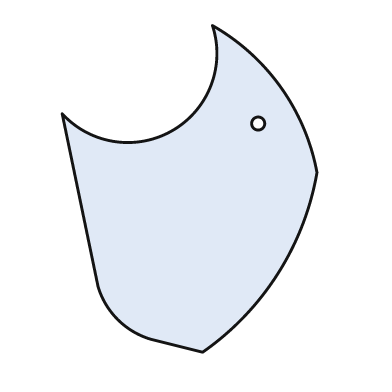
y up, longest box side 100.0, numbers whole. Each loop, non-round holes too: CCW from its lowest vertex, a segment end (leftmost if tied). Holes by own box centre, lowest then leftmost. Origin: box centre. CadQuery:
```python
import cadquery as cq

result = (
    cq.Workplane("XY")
    .moveTo(4.0, -50.0)
    .threePointArc((27.0, -26.0), (39.0, 5.0))
    .threePointArc((28.0, 31.0), (7.0, 50.0))
    .threePointArc((-5.0, 18.0), (-39.0, 23.0))
    .lineTo(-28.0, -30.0)
    .threePointArc((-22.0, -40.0), (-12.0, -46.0))
    .close()
    .moveTo(21.0, 20.0)
    .circle(2.0)
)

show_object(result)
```